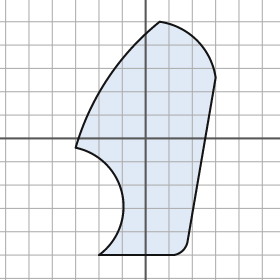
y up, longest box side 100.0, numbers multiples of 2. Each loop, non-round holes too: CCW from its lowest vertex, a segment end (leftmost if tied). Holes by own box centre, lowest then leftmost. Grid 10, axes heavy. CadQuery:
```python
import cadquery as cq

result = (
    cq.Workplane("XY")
    .moveTo(-20.0, -50.0)
    .lineTo(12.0, -50.0)
    .threePointArc((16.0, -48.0), (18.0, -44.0))
    .lineTo(30.0, 26.0)
    .threePointArc((22.0, 42.0), (6.0, 50.0))
    .threePointArc((-16.0, 26.0), (-30.0, -4.0))
    .threePointArc((-10.0, -24.0), (-20.0, -50.0))
    .close()
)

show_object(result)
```